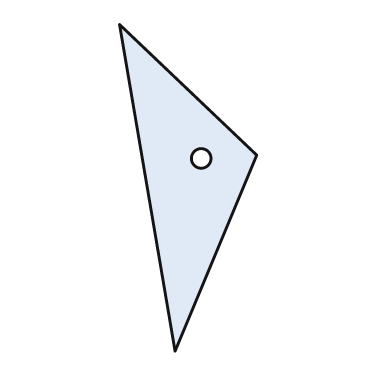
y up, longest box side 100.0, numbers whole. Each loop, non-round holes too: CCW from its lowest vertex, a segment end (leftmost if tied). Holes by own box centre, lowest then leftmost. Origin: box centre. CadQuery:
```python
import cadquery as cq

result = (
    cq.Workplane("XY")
    .moveTo(-4.0, -50.0)
    .lineTo(21.0, 10.0)
    .lineTo(-21.0, 50.0)
    .close()
    .moveTo(4.0, 9.0)
    .circle(3.0)
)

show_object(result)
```